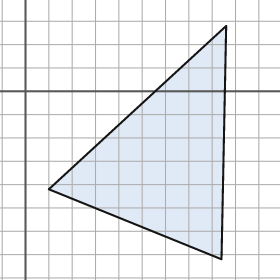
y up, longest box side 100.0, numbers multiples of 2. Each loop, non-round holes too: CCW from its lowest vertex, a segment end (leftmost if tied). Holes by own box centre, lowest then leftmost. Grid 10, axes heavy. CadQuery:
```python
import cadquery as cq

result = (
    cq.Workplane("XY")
    .moveTo(84.0, -72.0)
    .lineTo(86.0, 28.0)
    .lineTo(10.0, -42.0)
    .close()
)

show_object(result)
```